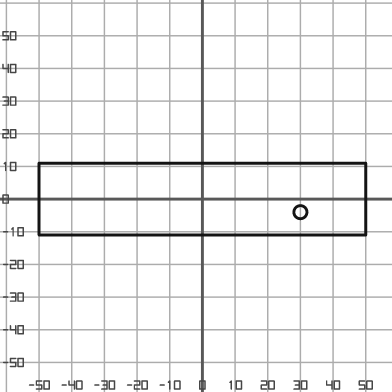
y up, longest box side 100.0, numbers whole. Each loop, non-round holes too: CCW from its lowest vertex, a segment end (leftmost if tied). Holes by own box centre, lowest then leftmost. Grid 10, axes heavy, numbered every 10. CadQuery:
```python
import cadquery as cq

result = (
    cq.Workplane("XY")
    .moveTo(-50.0, -11.0)
    .lineTo(50.0, -11.0)
    .lineTo(50.0, 11.0)
    .lineTo(-50.0, 11.0)
    .close()
    .moveTo(30.0, -4.0)
    .circle(2.0)
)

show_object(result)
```